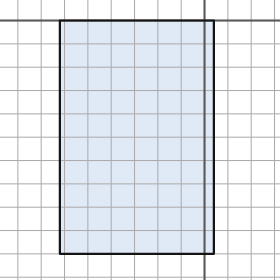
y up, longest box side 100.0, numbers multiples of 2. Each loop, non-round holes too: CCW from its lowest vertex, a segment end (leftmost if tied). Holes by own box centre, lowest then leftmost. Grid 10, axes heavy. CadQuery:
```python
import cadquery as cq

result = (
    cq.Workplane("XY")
    .moveTo(-62.0, -100.0)
    .lineTo(4.0, -100.0)
    .lineTo(4.0, 0.0)
    .lineTo(-62.0, 0.0)
    .close()
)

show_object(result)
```